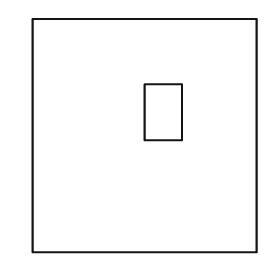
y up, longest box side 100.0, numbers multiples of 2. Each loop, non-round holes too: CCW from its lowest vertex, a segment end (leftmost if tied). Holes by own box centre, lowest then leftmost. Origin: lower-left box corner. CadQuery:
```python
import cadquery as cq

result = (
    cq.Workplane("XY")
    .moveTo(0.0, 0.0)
    .lineTo(96.0, 0.0)
    .lineTo(96.0, 100.0)
    .lineTo(0.0, 100.0)
    .close()
    .moveTo(48.0, 48.0)
    .lineTo(64.0, 48.0)
    .lineTo(64.0, 72.0)
    .lineTo(48.0, 72.0)
    .close()
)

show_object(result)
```